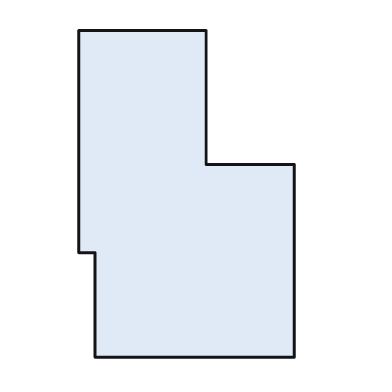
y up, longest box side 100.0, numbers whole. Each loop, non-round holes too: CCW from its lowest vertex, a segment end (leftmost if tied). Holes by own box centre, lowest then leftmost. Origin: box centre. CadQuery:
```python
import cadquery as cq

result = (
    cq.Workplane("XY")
    .moveTo(-28.0, -50.0)
    .lineTo(33.0, -50.0)
    .lineTo(33.0, 9.0)
    .lineTo(6.0, 9.0)
    .lineTo(6.0, 50.0)
    .lineTo(-33.0, 50.0)
    .lineTo(-33.0, -18.0)
    .lineTo(-28.0, -18.0)
    .close()
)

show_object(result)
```